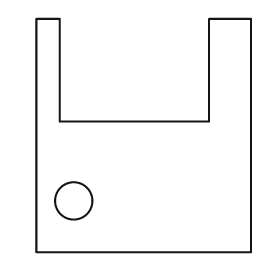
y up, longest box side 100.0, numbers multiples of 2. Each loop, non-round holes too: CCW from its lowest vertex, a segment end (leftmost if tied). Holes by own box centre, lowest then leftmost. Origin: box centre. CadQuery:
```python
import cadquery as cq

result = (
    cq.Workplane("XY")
    .moveTo(-46.0, -50.0)
    .lineTo(46.0, -50.0)
    .lineTo(46.0, 50.0)
    .lineTo(28.0, 50.0)
    .lineTo(28.0, 6.0)
    .lineTo(-36.0, 6.0)
    .lineTo(-36.0, 50.0)
    .lineTo(-46.0, 50.0)
    .close()
    .moveTo(-30.0, -28.0)
    .circle(8.0)
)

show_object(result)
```